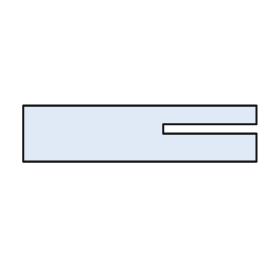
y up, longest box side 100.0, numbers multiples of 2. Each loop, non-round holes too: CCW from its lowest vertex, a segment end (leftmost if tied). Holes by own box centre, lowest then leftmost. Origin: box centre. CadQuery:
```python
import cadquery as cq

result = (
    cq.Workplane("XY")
    .moveTo(-50.0, -12.0)
    .lineTo(50.0, -12.0)
    .lineTo(50.0, 0.0)
    .lineTo(10.0, 0.0)
    .lineTo(10.0, 4.0)
    .lineTo(50.0, 4.0)
    .lineTo(50.0, 12.0)
    .lineTo(-50.0, 12.0)
    .close()
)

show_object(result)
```